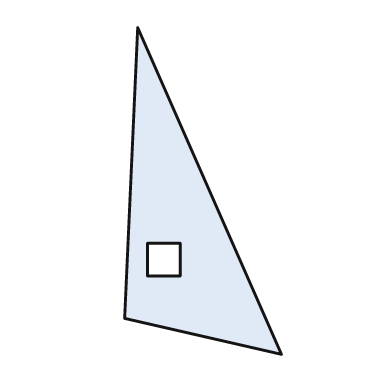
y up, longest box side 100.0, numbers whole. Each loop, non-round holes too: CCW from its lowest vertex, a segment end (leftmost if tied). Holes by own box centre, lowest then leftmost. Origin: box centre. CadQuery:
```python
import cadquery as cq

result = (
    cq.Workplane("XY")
    .moveTo(24.0, -50.0)
    .lineTo(-20.0, 50.0)
    .lineTo(-24.0, -39.0)
    .close()
    .moveTo(-17.0, -26.0)
    .lineTo(-7.0, -26.0)
    .lineTo(-7.0, -16.0)
    .lineTo(-17.0, -16.0)
    .close()
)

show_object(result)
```